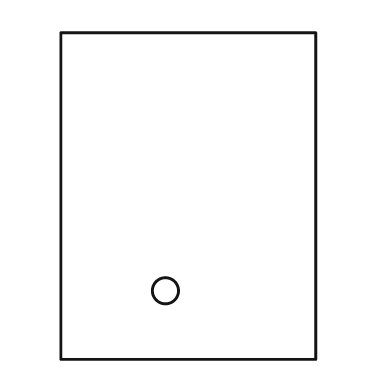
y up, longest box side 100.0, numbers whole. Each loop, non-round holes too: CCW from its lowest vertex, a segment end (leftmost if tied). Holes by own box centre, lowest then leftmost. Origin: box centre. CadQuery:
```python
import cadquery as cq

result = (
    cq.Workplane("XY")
    .moveTo(-39.0, -50.0)
    .lineTo(39.0, -50.0)
    .lineTo(39.0, 50.0)
    .lineTo(-39.0, 50.0)
    .close()
    .moveTo(-7.0, -29.0)
    .circle(4.0)
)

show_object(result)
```